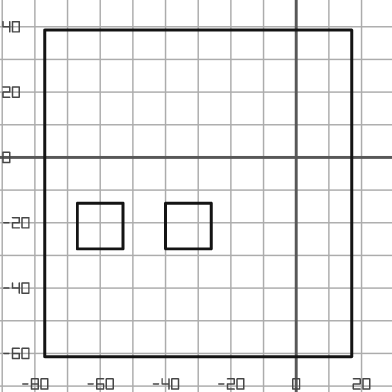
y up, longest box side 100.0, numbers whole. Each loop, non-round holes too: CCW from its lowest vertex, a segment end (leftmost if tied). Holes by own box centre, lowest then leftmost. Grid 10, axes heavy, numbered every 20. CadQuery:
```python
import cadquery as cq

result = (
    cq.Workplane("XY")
    .moveTo(-77.0, -61.0)
    .lineTo(17.0, -61.0)
    .lineTo(17.0, 39.0)
    .lineTo(-77.0, 39.0)
    .close()
    .moveTo(-67.0, -28.0)
    .lineTo(-53.0, -28.0)
    .lineTo(-53.0, -14.0)
    .lineTo(-67.0, -14.0)
    .close()
    .moveTo(-40.0, -28.0)
    .lineTo(-26.0, -28.0)
    .lineTo(-26.0, -14.0)
    .lineTo(-40.0, -14.0)
    .close()
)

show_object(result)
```